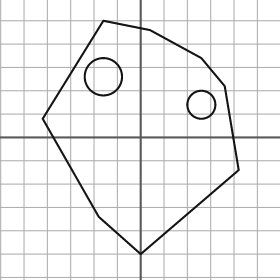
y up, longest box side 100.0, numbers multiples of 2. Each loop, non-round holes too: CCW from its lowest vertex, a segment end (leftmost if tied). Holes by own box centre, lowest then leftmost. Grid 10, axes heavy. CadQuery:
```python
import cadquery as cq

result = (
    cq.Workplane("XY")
    .moveTo(0.0, -50.0)
    .lineTo(42.0, -14.0)
    .lineTo(36.0, 22.0)
    .lineTo(26.0, 34.0)
    .lineTo(4.0, 46.0)
    .lineTo(-16.0, 50.0)
    .lineTo(-42.0, 8.0)
    .lineTo(-18.0, -34.0)
    .close()
    .moveTo(26.0, 14.0)
    .circle(6.0)
    .moveTo(-16.0, 26.0)
    .circle(8.0)
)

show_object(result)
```